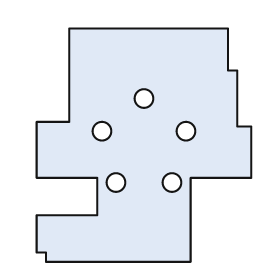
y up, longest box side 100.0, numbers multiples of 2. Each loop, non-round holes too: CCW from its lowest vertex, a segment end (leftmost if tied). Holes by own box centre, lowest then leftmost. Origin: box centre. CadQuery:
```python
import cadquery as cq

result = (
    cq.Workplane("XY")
    .moveTo(-42.0, -50.0)
    .lineTo(20.0, -50.0)
    .lineTo(20.0, -14.0)
    .lineTo(46.0, -14.0)
    .lineTo(46.0, 8.0)
    .lineTo(40.0, 8.0)
    .lineTo(40.0, 32.0)
    .lineTo(36.0, 32.0)
    .lineTo(36.0, 50.0)
    .lineTo(-32.0, 50.0)
    .lineTo(-32.0, 10.0)
    .lineTo(-46.0, 10.0)
    .lineTo(-46.0, -14.0)
    .lineTo(-20.0, -14.0)
    .lineTo(-20.0, -30.0)
    .lineTo(-46.0, -30.0)
    .lineTo(-46.0, -46.0)
    .lineTo(-42.0, -46.0)
    .close()
    .moveTo(-12.0, -16.0)
    .circle(4.0)
    .moveTo(12.0, -16.0)
    .circle(4.0)
    .moveTo(-18.0, 6.0)
    .circle(4.0)
    .moveTo(18.0, 6.0)
    .circle(4.0)
    .moveTo(0.0, 20.0)
    .circle(4.0)
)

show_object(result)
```